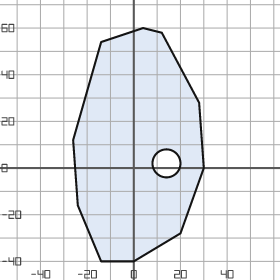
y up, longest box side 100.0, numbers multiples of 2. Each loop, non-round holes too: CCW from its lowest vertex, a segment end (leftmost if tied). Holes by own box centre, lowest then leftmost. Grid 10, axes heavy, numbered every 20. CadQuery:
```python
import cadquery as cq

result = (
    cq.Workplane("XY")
    .moveTo(-14.0, -40.0)
    .lineTo(0.0, -40.0)
    .lineTo(20.0, -28.0)
    .lineTo(30.0, 0.0)
    .lineTo(28.0, 28.0)
    .lineTo(12.0, 58.0)
    .lineTo(4.0, 60.0)
    .lineTo(-14.0, 54.0)
    .lineTo(-26.0, 12.0)
    .lineTo(-24.0, -16.0)
    .close()
    .moveTo(14.0, 2.0)
    .circle(6.0)
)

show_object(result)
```